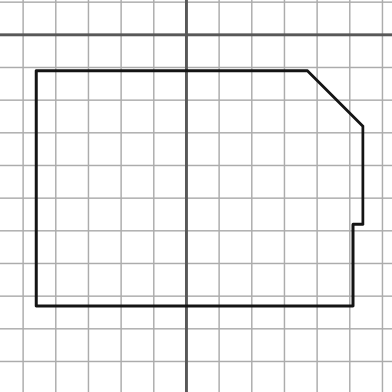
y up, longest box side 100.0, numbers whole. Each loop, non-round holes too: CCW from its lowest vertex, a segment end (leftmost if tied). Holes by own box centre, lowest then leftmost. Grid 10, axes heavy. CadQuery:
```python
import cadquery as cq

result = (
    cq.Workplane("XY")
    .moveTo(-46.0, -83.0)
    .lineTo(51.0, -83.0)
    .lineTo(51.0, -58.0)
    .lineTo(54.0, -58.0)
    .lineTo(54.0, -28.0)
    .lineTo(37.0, -11.0)
    .lineTo(-46.0, -11.0)
    .close()
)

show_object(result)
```